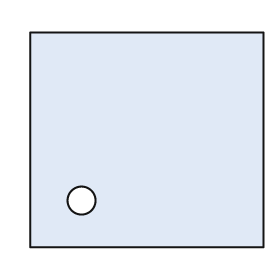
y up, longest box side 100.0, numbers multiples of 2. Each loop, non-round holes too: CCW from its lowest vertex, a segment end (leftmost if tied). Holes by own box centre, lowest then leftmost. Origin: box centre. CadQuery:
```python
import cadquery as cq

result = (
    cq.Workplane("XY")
    .moveTo(-50.0, -46.0)
    .lineTo(50.0, -46.0)
    .lineTo(50.0, 46.0)
    .lineTo(-50.0, 46.0)
    .close()
    .moveTo(-28.0, -26.0)
    .circle(6.0)
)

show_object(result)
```